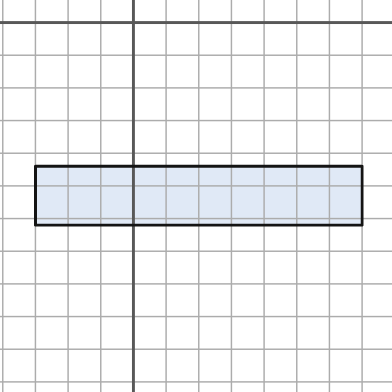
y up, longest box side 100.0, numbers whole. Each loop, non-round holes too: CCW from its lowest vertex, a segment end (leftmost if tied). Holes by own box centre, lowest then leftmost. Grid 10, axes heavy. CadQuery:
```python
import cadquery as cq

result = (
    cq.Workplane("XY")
    .moveTo(-30.0, -62.0)
    .lineTo(70.0, -62.0)
    .lineTo(70.0, -44.0)
    .lineTo(-30.0, -44.0)
    .close()
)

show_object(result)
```